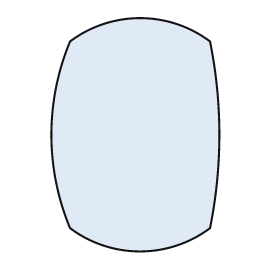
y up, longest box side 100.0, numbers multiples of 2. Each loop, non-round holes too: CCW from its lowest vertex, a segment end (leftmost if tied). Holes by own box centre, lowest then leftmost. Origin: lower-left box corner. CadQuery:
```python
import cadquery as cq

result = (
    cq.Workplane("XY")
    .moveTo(8.0, 10.0)
    .threePointArc((38.0, 0.0), (68.0, 10.0))
    .threePointArc((72.0, 50.0), (68.0, 90.0))
    .threePointArc((38.0, 100.0), (8.0, 90.0))
    .threePointArc((0.0, 50.0), (8.0, 10.0))
    .close()
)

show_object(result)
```